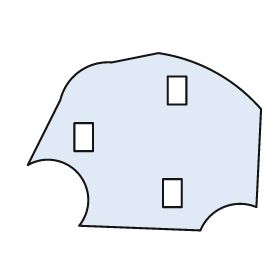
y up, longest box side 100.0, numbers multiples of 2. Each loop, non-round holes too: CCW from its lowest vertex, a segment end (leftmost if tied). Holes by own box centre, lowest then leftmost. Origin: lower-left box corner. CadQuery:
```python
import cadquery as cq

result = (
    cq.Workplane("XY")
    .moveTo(74.0, 0.0)
    .threePointArc((84.0, 10.0), (98.0, 10.0))
    .lineTo(100.0, 52.0)
    .threePointArc((80.0, 68.0), (56.0, 76.0))
    .lineTo(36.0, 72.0)
    .threePointArc((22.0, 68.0), (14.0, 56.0))
    .lineTo(0.0, 28.0)
    .threePointArc((22.0, 24.0), (22.0, 2.0))
    .close()
    .moveTo(58.0, 10.0)
    .lineTo(66.0, 10.0)
    .lineTo(66.0, 22.0)
    .lineTo(58.0, 22.0)
    .close()
    .moveTo(20.0, 34.0)
    .lineTo(28.0, 34.0)
    .lineTo(28.0, 46.0)
    .lineTo(20.0, 46.0)
    .close()
    .moveTo(60.0, 54.0)
    .lineTo(68.0, 54.0)
    .lineTo(68.0, 66.0)
    .lineTo(60.0, 66.0)
    .close()
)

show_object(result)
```